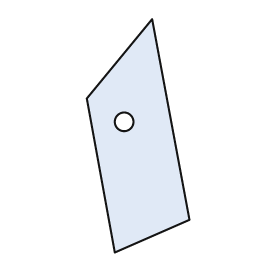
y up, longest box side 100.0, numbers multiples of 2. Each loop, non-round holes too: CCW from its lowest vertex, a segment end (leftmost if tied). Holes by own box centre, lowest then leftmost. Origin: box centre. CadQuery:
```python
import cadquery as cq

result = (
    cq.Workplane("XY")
    .moveTo(-10.0, -50.0)
    .lineTo(22.0, -36.0)
    .lineTo(6.0, 50.0)
    .lineTo(-22.0, 16.0)
    .close()
    .moveTo(-6.0, 6.0)
    .circle(4.0)
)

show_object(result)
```